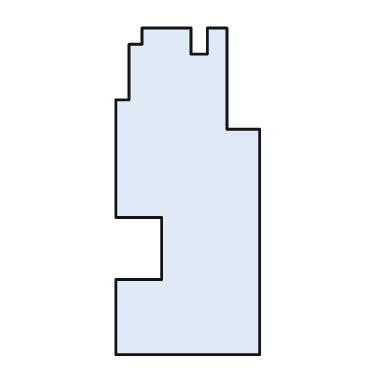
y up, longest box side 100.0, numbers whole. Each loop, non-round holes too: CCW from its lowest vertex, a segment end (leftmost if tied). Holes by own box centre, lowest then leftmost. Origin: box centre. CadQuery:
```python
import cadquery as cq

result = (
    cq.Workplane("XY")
    .moveTo(-22.0, -50.0)
    .lineTo(22.0, -50.0)
    .lineTo(22.0, 19.0)
    .lineTo(12.0, 19.0)
    .lineTo(12.0, 50.0)
    .lineTo(6.0, 50.0)
    .lineTo(6.0, 42.0)
    .lineTo(1.0, 42.0)
    .lineTo(1.0, 50.0)
    .lineTo(-14.0, 50.0)
    .lineTo(-14.0, 45.0)
    .lineTo(-18.0, 45.0)
    .lineTo(-18.0, 28.0)
    .lineTo(-22.0, 28.0)
    .lineTo(-22.0, -8.0)
    .lineTo(-8.0, -8.0)
    .lineTo(-8.0, -27.0)
    .lineTo(-22.0, -27.0)
    .close()
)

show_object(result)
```